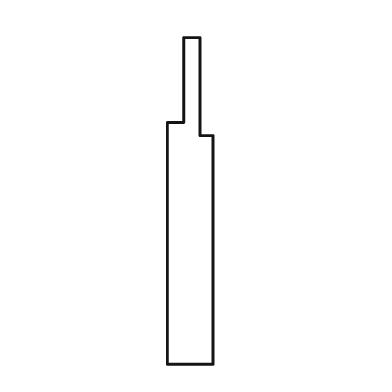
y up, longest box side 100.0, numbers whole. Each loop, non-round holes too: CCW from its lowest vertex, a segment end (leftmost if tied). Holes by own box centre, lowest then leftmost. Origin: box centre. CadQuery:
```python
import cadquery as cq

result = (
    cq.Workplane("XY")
    .moveTo(-7.0, -50.0)
    .lineTo(7.0, -50.0)
    .lineTo(7.0, 20.0)
    .lineTo(3.0, 20.0)
    .lineTo(3.0, 50.0)
    .lineTo(-2.0, 50.0)
    .lineTo(-2.0, 24.0)
    .lineTo(-7.0, 24.0)
    .close()
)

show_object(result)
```